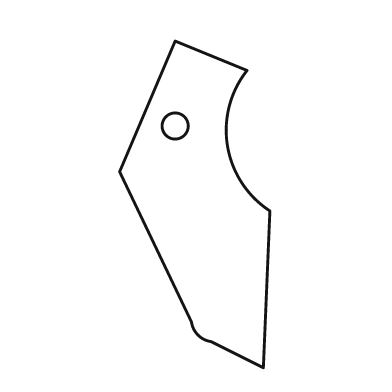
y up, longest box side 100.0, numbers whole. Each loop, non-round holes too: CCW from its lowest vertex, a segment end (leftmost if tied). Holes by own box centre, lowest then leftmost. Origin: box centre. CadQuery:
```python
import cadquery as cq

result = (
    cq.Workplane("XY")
    .moveTo(21.0, -50.0)
    .lineTo(23.0, -2.0)
    .threePointArc((10.0, 18.0), (16.0, 41.0))
    .lineTo(-6.0, 50.0)
    .lineTo(-23.0, 10.0)
    .lineTo(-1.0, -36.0)
    .threePointArc((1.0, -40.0), (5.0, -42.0))
    .close()
    .moveTo(-6.0, 24.0)
    .circle(4.0)
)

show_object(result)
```